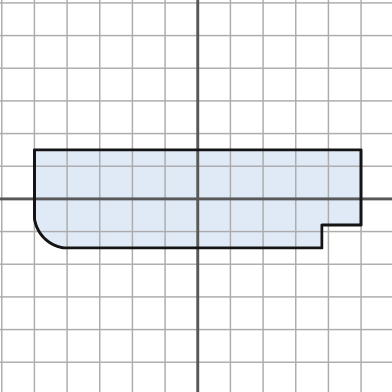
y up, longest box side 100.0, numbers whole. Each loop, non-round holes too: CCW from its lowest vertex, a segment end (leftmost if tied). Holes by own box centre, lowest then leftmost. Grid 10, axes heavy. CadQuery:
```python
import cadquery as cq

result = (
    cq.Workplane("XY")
    .moveTo(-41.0, -15.0)
    .lineTo(38.0, -15.0)
    .lineTo(38.0, -8.0)
    .lineTo(50.0, -8.0)
    .lineTo(50.0, 15.0)
    .lineTo(-50.0, 15.0)
    .lineTo(-50.0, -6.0)
    .threePointArc((-47.0, -12.0), (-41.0, -15.0))
    .close()
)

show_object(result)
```